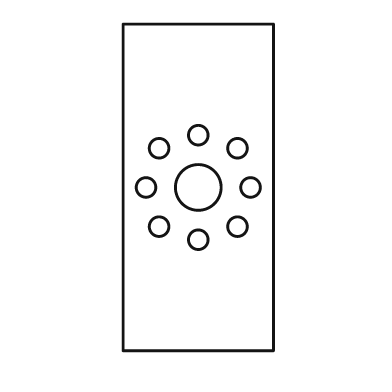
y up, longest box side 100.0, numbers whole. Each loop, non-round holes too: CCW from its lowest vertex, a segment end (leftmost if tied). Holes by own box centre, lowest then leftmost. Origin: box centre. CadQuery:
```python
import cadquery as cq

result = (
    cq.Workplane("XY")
    .moveTo(-23.0, -50.0)
    .lineTo(23.0, -50.0)
    .lineTo(23.0, 50.0)
    .lineTo(-23.0, 50.0)
    .close()
    .moveTo(0.0, -16.0)
    .circle(3.0)
    .moveTo(-12.0, -12.0)
    .circle(3.0)
    .moveTo(12.0, -12.0)
    .circle(3.0)
    .moveTo(-16.0, 0.0)
    .circle(3.0)
    .moveTo(0.0, 0.0)
    .circle(7.0)
    .moveTo(16.0, 0.0)
    .circle(3.0)
    .moveTo(-12.0, 12.0)
    .circle(3.0)
    .moveTo(12.0, 12.0)
    .circle(3.0)
    .moveTo(0.0, 16.0)
    .circle(3.0)
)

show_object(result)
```